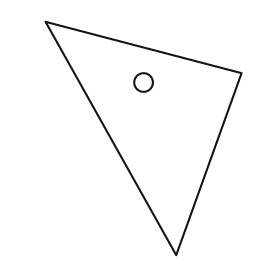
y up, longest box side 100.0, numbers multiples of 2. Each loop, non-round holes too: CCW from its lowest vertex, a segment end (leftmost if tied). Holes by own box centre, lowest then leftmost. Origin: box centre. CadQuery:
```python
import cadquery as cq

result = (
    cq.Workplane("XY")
    .moveTo(14.0, -50.0)
    .lineTo(42.0, 28.0)
    .lineTo(-42.0, 50.0)
    .close()
    .moveTo(0.0, 24.0)
    .circle(4.0)
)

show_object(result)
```